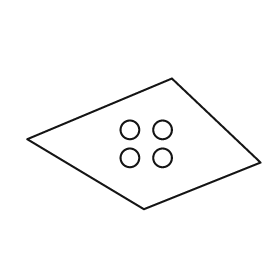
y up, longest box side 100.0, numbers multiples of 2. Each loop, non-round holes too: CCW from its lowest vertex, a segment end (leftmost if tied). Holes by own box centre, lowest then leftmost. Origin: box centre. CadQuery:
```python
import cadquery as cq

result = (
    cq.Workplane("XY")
    .moveTo(0.0, -28.0)
    .lineTo(50.0, -8.0)
    .lineTo(12.0, 28.0)
    .lineTo(-50.0, 2.0)
    .close()
    .moveTo(-6.0, -6.0)
    .circle(4.0)
    .moveTo(8.0, -6.0)
    .circle(4.0)
    .moveTo(-6.0, 6.0)
    .circle(4.0)
    .moveTo(8.0, 6.0)
    .circle(4.0)
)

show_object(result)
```